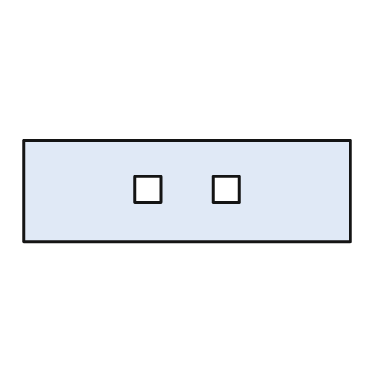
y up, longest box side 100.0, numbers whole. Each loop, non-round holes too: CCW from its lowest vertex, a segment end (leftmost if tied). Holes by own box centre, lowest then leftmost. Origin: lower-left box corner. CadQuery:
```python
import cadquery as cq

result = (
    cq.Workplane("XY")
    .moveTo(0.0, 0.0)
    .lineTo(100.0, 0.0)
    .lineTo(100.0, 31.0)
    .lineTo(0.0, 31.0)
    .close()
    .moveTo(34.0, 12.0)
    .lineTo(42.0, 12.0)
    .lineTo(42.0, 20.0)
    .lineTo(34.0, 20.0)
    .close()
    .moveTo(58.0, 12.0)
    .lineTo(66.0, 12.0)
    .lineTo(66.0, 20.0)
    .lineTo(58.0, 20.0)
    .close()
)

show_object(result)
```